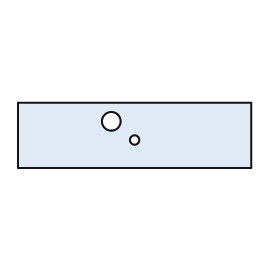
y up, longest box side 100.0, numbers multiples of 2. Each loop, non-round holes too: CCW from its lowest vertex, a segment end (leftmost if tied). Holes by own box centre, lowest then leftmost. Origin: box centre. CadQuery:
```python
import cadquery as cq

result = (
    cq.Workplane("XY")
    .moveTo(-50.0, -14.0)
    .lineTo(50.0, -14.0)
    .lineTo(50.0, 14.0)
    .lineTo(-50.0, 14.0)
    .close()
    .moveTo(0.0, -2.0)
    .circle(2.0)
    .moveTo(-10.0, 6.0)
    .circle(4.0)
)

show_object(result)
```